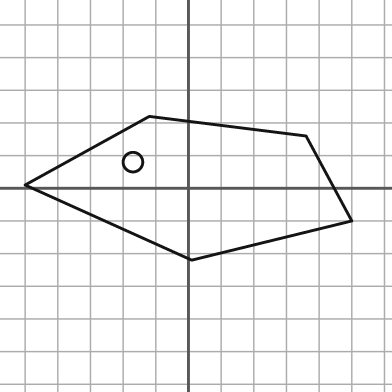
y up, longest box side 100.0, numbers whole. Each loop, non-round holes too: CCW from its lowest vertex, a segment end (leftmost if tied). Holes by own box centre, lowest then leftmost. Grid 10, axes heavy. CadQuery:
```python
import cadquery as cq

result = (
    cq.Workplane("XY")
    .moveTo(1.0, -22.0)
    .lineTo(50.0, -10.0)
    .lineTo(36.0, 16.0)
    .lineTo(-12.0, 22.0)
    .lineTo(-50.0, 1.0)
    .close()
    .moveTo(-17.0, 8.0)
    .circle(3.0)
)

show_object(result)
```